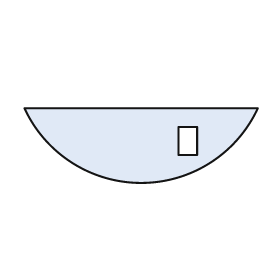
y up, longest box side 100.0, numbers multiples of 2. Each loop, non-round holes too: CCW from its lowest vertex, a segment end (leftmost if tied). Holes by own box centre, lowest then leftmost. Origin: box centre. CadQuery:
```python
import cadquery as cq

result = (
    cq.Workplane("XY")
    .moveTo(-50.0, 16.0)
    .threePointArc((0.0, -16.0), (50.0, 16.0))
    .close()
    .moveTo(16.0, -4.0)
    .lineTo(24.0, -4.0)
    .lineTo(24.0, 8.0)
    .lineTo(16.0, 8.0)
    .close()
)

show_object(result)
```